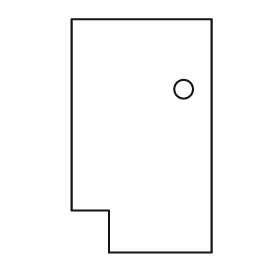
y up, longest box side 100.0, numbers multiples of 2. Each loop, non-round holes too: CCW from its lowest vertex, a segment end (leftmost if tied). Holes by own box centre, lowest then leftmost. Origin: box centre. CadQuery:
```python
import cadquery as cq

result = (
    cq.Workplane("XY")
    .moveTo(-14.0, -50.0)
    .lineTo(30.0, -50.0)
    .lineTo(30.0, 50.0)
    .lineTo(-30.0, 50.0)
    .lineTo(-30.0, -32.0)
    .lineTo(-14.0, -32.0)
    .close()
    .moveTo(18.0, 20.0)
    .circle(4.0)
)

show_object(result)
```